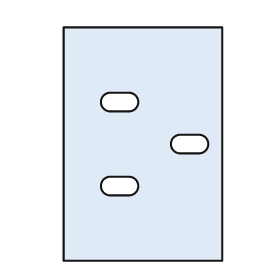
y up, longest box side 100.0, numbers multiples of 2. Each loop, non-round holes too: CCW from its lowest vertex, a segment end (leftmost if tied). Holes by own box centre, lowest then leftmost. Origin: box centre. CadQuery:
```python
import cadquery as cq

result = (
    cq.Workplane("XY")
    .moveTo(-34.0, -50.0)
    .lineTo(34.0, -50.0)
    .lineTo(34.0, 50.0)
    .lineTo(-34.0, 50.0)
    .close()
    .moveTo(-14.0, -22.0)
    .lineTo(-6.0, -22.0)
    .threePointArc((-2.0, -18.0), (-6.0, -14.0))
    .lineTo(-14.0, -14.0)
    .threePointArc((-18.0, -18.0), (-14.0, -22.0))
    .close()
    .moveTo(16.0, -4.0)
    .lineTo(24.0, -4.0)
    .threePointArc((28.0, 0.0), (24.0, 4.0))
    .lineTo(16.0, 4.0)
    .threePointArc((12.0, 0.0), (16.0, -4.0))
    .close()
    .moveTo(-14.0, 14.0)
    .lineTo(-6.0, 14.0)
    .threePointArc((-2.0, 18.0), (-6.0, 22.0))
    .lineTo(-14.0, 22.0)
    .threePointArc((-18.0, 18.0), (-14.0, 14.0))
    .close()
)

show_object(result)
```